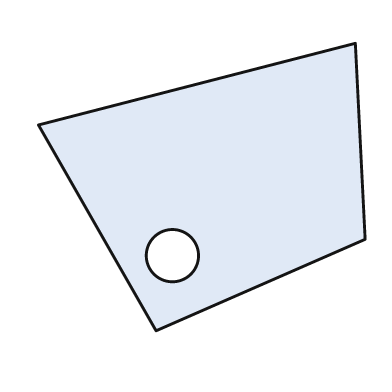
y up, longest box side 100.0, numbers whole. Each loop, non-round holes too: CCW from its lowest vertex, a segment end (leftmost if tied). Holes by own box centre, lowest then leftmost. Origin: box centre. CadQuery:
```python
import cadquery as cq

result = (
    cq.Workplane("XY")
    .moveTo(-14.0, -44.0)
    .lineTo(50.0, -16.0)
    .lineTo(47.0, 44.0)
    .lineTo(-50.0, 19.0)
    .close()
    .moveTo(-9.0, -21.0)
    .circle(8.0)
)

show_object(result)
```